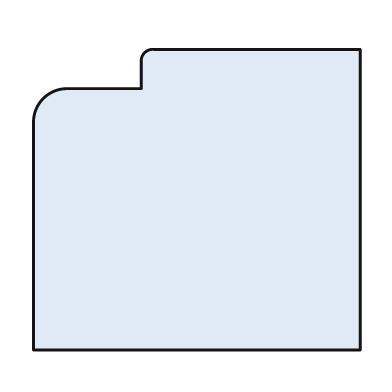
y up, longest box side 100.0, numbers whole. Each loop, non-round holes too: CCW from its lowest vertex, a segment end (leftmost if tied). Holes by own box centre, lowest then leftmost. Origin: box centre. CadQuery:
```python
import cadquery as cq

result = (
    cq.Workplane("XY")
    .moveTo(-50.0, -46.0)
    .lineTo(50.0, -46.0)
    .lineTo(50.0, 46.0)
    .lineTo(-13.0, 46.0)
    .threePointArc((-16.0, 45.0), (-17.0, 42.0))
    .lineTo(-17.0, 34.0)
    .lineTo(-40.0, 34.0)
    .threePointArc((-47.0, 31.0), (-50.0, 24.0))
    .close()
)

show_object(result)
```